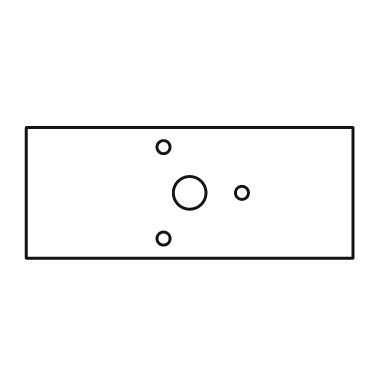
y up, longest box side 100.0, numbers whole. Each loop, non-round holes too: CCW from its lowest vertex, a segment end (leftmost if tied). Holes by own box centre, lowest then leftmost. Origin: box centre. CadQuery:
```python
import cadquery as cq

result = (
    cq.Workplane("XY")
    .moveTo(-50.0, -20.0)
    .lineTo(50.0, -20.0)
    .lineTo(50.0, 20.0)
    .lineTo(-50.0, 20.0)
    .close()
    .moveTo(-8.0, -14.0)
    .circle(2.0)
    .moveTo(0.0, 0.0)
    .circle(5.0)
    .moveTo(16.0, 0.0)
    .circle(2.0)
    .moveTo(-8.0, 14.0)
    .circle(2.0)
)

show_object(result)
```